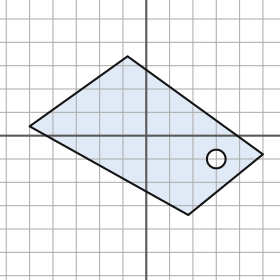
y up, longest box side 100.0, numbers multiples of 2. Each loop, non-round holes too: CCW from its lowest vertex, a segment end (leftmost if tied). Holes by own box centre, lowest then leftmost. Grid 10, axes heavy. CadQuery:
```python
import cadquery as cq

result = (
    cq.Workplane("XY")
    .moveTo(18.0, -34.0)
    .lineTo(50.0, -8.0)
    .lineTo(-8.0, 34.0)
    .lineTo(-50.0, 4.0)
    .close()
    .moveTo(30.0, -10.0)
    .circle(4.0)
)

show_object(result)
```